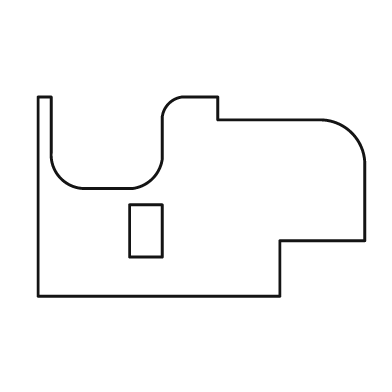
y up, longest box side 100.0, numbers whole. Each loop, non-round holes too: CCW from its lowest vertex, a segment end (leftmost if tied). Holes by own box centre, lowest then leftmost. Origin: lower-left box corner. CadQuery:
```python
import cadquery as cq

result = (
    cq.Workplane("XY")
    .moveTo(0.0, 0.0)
    .lineTo(74.0, 0.0)
    .lineTo(74.0, 17.0)
    .lineTo(100.0, 17.0)
    .lineTo(100.0, 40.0)
    .threePointArc((96.0, 50.0), (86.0, 54.0))
    .lineTo(55.0, 54.0)
    .lineTo(55.0, 61.0)
    .lineTo(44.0, 61.0)
    .threePointArc((40.0, 59.0), (38.0, 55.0))
    .lineTo(38.0, 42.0)
    .threePointArc((35.0, 36.0), (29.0, 33.0))
    .lineTo(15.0, 33.0)
    .threePointArc((7.0, 36.0), (4.0, 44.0))
    .lineTo(4.0, 61.0)
    .lineTo(0.0, 61.0)
    .close()
    .moveTo(28.0, 12.0)
    .lineTo(38.0, 12.0)
    .lineTo(38.0, 28.0)
    .lineTo(28.0, 28.0)
    .close()
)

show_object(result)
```